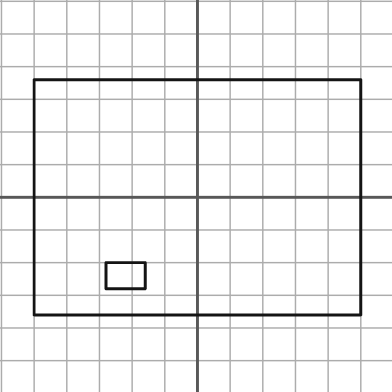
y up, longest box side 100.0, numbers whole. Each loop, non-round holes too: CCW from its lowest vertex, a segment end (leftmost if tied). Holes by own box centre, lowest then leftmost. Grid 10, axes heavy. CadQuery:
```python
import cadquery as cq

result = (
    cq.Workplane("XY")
    .moveTo(-50.0, -36.0)
    .lineTo(50.0, -36.0)
    .lineTo(50.0, 36.0)
    .lineTo(-50.0, 36.0)
    .close()
    .moveTo(-28.0, -28.0)
    .lineTo(-16.0, -28.0)
    .lineTo(-16.0, -20.0)
    .lineTo(-28.0, -20.0)
    .close()
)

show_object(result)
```